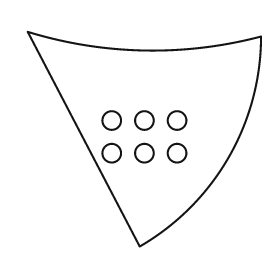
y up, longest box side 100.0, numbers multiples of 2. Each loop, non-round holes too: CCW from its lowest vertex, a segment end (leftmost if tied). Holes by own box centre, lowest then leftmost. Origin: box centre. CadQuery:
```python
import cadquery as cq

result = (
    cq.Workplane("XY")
    .moveTo(-2.0, -46.0)
    .threePointArc((36.0, -8.0), (50.0, 44.0))
    .threePointArc((0.0, 38.0), (-50.0, 46.0))
    .close()
    .moveTo(-14.0, -6.0)
    .circle(4.0)
    .moveTo(0.0, -6.0)
    .circle(4.0)
    .moveTo(14.0, -6.0)
    .circle(4.0)
    .moveTo(-14.0, 8.0)
    .circle(4.0)
    .moveTo(0.0, 8.0)
    .circle(4.0)
    .moveTo(14.0, 8.0)
    .circle(4.0)
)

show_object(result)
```